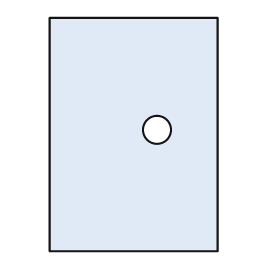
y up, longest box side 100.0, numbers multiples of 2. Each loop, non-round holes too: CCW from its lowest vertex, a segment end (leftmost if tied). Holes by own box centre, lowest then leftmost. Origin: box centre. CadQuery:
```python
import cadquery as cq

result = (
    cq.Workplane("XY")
    .moveTo(-36.0, -50.0)
    .lineTo(36.0, -50.0)
    .lineTo(36.0, 50.0)
    .lineTo(-36.0, 50.0)
    .close()
    .moveTo(10.0, 2.0)
    .circle(6.0)
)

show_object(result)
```